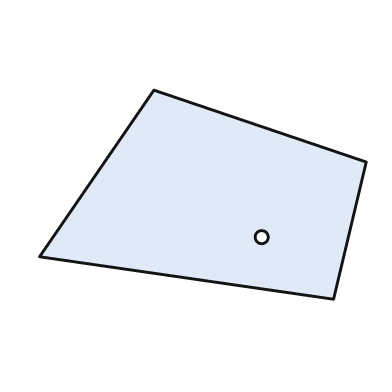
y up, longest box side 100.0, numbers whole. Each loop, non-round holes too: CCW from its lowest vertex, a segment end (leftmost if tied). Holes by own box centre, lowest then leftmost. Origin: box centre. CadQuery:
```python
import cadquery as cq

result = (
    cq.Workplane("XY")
    .moveTo(40.0, -32.0)
    .lineTo(50.0, 10.0)
    .lineTo(-15.0, 32.0)
    .lineTo(-50.0, -19.0)
    .close()
    .moveTo(18.0, -13.0)
    .circle(2.0)
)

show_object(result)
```